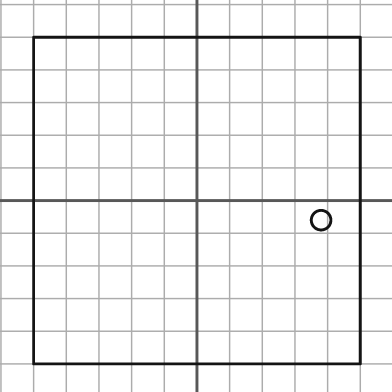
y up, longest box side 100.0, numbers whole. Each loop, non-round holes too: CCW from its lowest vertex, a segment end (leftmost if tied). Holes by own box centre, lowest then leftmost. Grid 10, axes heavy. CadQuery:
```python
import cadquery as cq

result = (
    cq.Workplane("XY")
    .moveTo(-50.0, -50.0)
    .lineTo(50.0, -50.0)
    .lineTo(50.0, 50.0)
    .lineTo(-50.0, 50.0)
    .close()
    .moveTo(38.0, -6.0)
    .circle(3.0)
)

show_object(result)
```